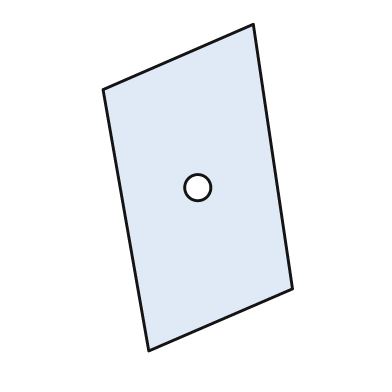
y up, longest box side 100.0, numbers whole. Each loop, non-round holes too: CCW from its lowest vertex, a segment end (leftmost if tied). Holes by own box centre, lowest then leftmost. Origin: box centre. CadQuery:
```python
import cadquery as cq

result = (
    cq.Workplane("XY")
    .moveTo(-15.0, -50.0)
    .lineTo(29.0, -31.0)
    .lineTo(17.0, 50.0)
    .lineTo(-29.0, 30.0)
    .close()
    .moveTo(0.0, 0.0)
    .circle(4.0)
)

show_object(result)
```